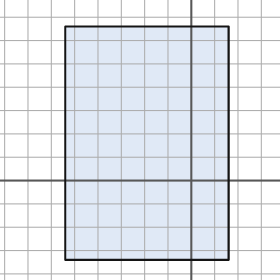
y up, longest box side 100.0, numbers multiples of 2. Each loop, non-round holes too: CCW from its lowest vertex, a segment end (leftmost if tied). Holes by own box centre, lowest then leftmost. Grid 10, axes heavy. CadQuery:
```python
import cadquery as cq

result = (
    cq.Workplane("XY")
    .moveTo(-54.0, -34.0)
    .lineTo(16.0, -34.0)
    .lineTo(16.0, 66.0)
    .lineTo(-54.0, 66.0)
    .close()
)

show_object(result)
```